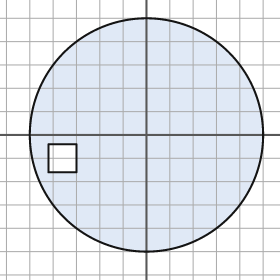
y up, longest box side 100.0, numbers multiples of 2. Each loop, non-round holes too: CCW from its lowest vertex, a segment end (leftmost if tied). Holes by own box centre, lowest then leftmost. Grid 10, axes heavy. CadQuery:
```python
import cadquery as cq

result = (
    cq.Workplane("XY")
    .moveTo(0.0, 0.0)
    .circle(50.0)
    .moveTo(-42.0, -16.0)
    .lineTo(-30.0, -16.0)
    .lineTo(-30.0, -4.0)
    .lineTo(-42.0, -4.0)
    .close()
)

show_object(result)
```